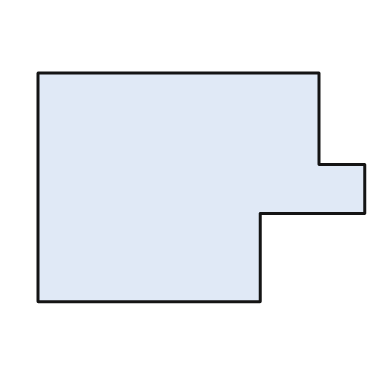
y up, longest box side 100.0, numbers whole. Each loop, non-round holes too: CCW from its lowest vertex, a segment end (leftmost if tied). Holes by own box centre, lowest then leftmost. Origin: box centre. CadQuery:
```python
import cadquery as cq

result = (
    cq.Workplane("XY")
    .moveTo(-50.0, -35.0)
    .lineTo(18.0, -35.0)
    .lineTo(18.0, -8.0)
    .lineTo(50.0, -8.0)
    .lineTo(50.0, 7.0)
    .lineTo(36.0, 7.0)
    .lineTo(36.0, 35.0)
    .lineTo(-50.0, 35.0)
    .close()
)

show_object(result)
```